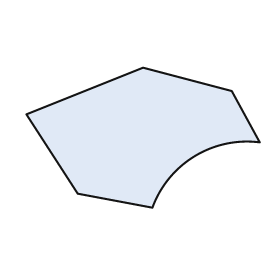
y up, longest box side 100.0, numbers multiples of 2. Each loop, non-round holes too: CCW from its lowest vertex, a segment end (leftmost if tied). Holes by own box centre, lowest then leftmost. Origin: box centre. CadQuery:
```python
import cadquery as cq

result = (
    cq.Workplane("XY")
    .moveTo(4.0, -30.0)
    .threePointArc((22.0, -8.0), (50.0, -2.0))
    .lineTo(38.0, 20.0)
    .lineTo(0.0, 30.0)
    .lineTo(-50.0, 10.0)
    .lineTo(-28.0, -24.0)
    .close()
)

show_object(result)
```